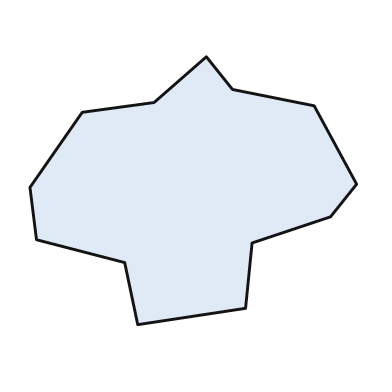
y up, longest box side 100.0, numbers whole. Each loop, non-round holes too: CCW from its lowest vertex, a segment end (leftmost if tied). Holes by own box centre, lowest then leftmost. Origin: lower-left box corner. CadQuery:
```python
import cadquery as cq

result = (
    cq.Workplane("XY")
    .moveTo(33.0, 0.0)
    .lineTo(66.0, 5.0)
    .lineTo(68.0, 25.0)
    .lineTo(92.0, 33.0)
    .lineTo(100.0, 43.0)
    .lineTo(87.0, 67.0)
    .lineTo(62.0, 72.0)
    .lineTo(54.0, 82.0)
    .lineTo(38.0, 68.0)
    .lineTo(16.0, 65.0)
    .lineTo(0.0, 42.0)
    .lineTo(2.0, 26.0)
    .lineTo(29.0, 19.0)
    .close()
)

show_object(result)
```